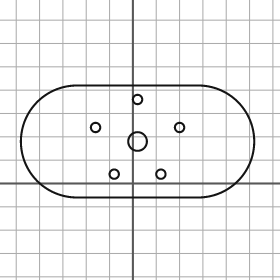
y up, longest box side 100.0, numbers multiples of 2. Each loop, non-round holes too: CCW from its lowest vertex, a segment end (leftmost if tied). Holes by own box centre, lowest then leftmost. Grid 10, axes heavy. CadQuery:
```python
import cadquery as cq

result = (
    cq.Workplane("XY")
    .moveTo(-24.0, -6.0)
    .lineTo(28.0, -6.0)
    .threePointArc((52.0, 18.0), (28.0, 42.0))
    .lineTo(-24.0, 42.0)
    .threePointArc((-48.0, 18.0), (-24.0, -6.0))
    .close()
    .moveTo(-8.0, 4.0)
    .circle(2.0)
    .moveTo(12.0, 4.0)
    .circle(2.0)
    .moveTo(2.0, 18.0)
    .circle(4.0)
    .moveTo(-16.0, 24.0)
    .circle(2.0)
    .moveTo(20.0, 24.0)
    .circle(2.0)
    .moveTo(2.0, 36.0)
    .circle(2.0)
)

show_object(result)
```